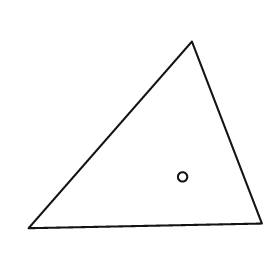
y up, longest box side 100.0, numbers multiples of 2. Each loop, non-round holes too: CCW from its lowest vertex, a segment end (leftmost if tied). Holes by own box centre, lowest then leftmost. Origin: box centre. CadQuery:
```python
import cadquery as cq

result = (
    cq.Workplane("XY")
    .moveTo(-50.0, -40.0)
    .lineTo(50.0, -38.0)
    .lineTo(20.0, 40.0)
    .close()
    .moveTo(16.0, -18.0)
    .circle(2.0)
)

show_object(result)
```